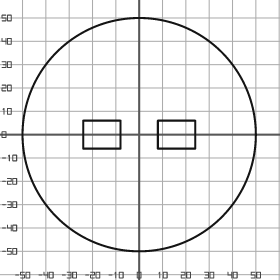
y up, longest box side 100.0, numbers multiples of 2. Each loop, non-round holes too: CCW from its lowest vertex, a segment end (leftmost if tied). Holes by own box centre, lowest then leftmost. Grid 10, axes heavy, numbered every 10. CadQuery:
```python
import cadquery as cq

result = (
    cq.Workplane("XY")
    .moveTo(0.0, 0.0)
    .circle(50.0)
    .moveTo(-24.0, -6.0)
    .lineTo(-8.0, -6.0)
    .lineTo(-8.0, 6.0)
    .lineTo(-24.0, 6.0)
    .close()
    .moveTo(8.0, -6.0)
    .lineTo(24.0, -6.0)
    .lineTo(24.0, 6.0)
    .lineTo(8.0, 6.0)
    .close()
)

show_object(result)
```